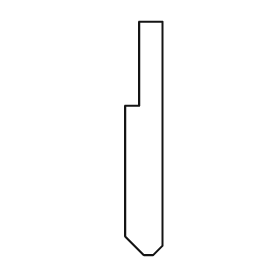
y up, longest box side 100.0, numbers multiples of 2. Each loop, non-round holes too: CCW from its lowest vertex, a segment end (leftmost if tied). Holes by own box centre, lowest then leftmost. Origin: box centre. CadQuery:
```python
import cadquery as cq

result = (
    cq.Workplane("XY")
    .moveTo(0.0, -50.0)
    .lineTo(4.0, -50.0)
    .lineTo(8.0, -46.0)
    .lineTo(8.0, 50.0)
    .lineTo(-2.0, 50.0)
    .lineTo(-2.0, 14.0)
    .lineTo(-8.0, 14.0)
    .lineTo(-8.0, -42.0)
    .close()
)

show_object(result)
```